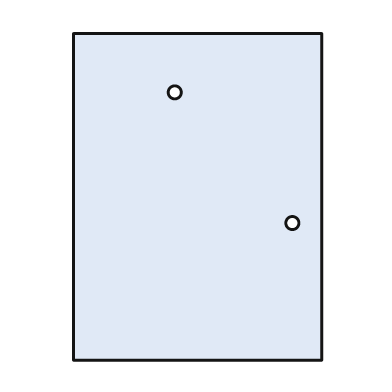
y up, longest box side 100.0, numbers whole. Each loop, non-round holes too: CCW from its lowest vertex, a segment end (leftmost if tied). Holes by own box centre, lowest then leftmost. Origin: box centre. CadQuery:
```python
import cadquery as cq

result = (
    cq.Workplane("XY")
    .moveTo(-38.0, -50.0)
    .lineTo(38.0, -50.0)
    .lineTo(38.0, 50.0)
    .lineTo(-38.0, 50.0)
    .close()
    .moveTo(29.0, -8.0)
    .circle(2.0)
    .moveTo(-7.0, 32.0)
    .circle(2.0)
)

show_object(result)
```